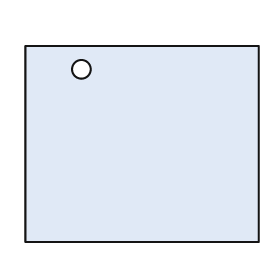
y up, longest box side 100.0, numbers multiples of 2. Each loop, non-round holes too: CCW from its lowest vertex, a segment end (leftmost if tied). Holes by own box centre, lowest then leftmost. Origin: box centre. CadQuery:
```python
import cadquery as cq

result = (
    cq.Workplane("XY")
    .moveTo(-50.0, -42.0)
    .lineTo(50.0, -42.0)
    .lineTo(50.0, 42.0)
    .lineTo(-50.0, 42.0)
    .close()
    .moveTo(-26.0, 32.0)
    .circle(4.0)
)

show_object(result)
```